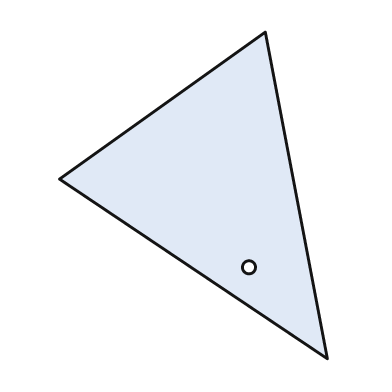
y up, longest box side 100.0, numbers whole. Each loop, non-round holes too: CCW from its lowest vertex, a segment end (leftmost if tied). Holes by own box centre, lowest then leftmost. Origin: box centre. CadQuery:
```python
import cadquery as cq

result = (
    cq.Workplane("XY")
    .moveTo(41.0, -50.0)
    .lineTo(22.0, 50.0)
    .lineTo(-41.0, 5.0)
    .close()
    .moveTo(17.0, -22.0)
    .circle(2.0)
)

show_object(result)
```